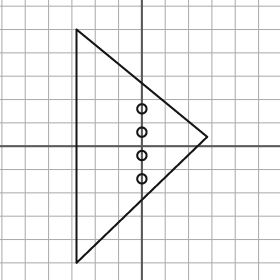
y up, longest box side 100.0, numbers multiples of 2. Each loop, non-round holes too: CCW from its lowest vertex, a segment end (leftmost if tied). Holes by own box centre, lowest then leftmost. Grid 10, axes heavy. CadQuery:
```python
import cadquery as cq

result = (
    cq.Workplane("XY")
    .moveTo(-28.0, -50.0)
    .lineTo(28.0, 4.0)
    .lineTo(-28.0, 50.0)
    .close()
    .moveTo(0.0, -14.0)
    .circle(2.0)
    .moveTo(0.0, -4.0)
    .circle(2.0)
    .moveTo(0.0, 6.0)
    .circle(2.0)
    .moveTo(0.0, 16.0)
    .circle(2.0)
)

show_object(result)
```